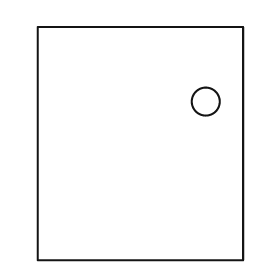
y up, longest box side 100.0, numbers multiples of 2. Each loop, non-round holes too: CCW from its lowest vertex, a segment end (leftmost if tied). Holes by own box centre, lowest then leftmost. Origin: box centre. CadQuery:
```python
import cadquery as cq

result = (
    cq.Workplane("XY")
    .moveTo(-44.0, -50.0)
    .lineTo(44.0, -50.0)
    .lineTo(44.0, 50.0)
    .lineTo(-44.0, 50.0)
    .close()
    .moveTo(28.0, 18.0)
    .circle(6.0)
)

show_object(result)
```